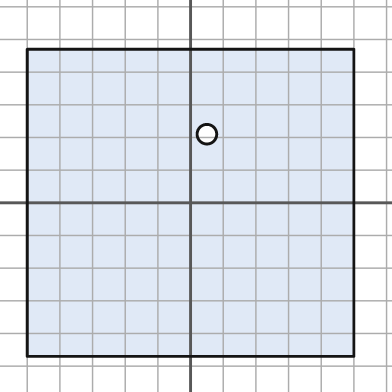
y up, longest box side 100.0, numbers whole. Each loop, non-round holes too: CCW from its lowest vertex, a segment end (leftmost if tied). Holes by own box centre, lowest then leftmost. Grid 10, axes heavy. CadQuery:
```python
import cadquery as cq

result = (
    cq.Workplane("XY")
    .moveTo(-50.0, -47.0)
    .lineTo(50.0, -47.0)
    .lineTo(50.0, 47.0)
    .lineTo(-50.0, 47.0)
    .close()
    .moveTo(5.0, 21.0)
    .circle(3.0)
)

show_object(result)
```